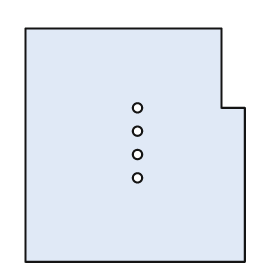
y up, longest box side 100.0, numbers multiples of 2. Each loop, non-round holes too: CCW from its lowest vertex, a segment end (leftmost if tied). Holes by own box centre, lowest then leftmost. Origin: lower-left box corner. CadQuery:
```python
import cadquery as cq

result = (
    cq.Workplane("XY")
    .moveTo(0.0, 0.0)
    .lineTo(94.0, 0.0)
    .lineTo(94.0, 66.0)
    .lineTo(84.0, 66.0)
    .lineTo(84.0, 100.0)
    .lineTo(0.0, 100.0)
    .close()
    .moveTo(48.0, 36.0)
    .circle(2.0)
    .moveTo(48.0, 46.0)
    .circle(2.0)
    .moveTo(48.0, 56.0)
    .circle(2.0)
    .moveTo(48.0, 66.0)
    .circle(2.0)
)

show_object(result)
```